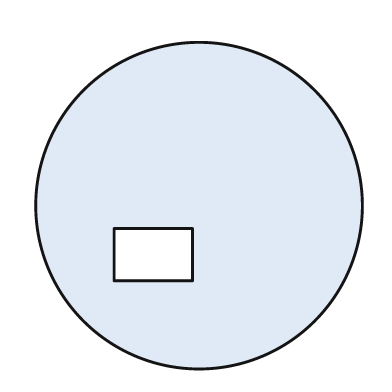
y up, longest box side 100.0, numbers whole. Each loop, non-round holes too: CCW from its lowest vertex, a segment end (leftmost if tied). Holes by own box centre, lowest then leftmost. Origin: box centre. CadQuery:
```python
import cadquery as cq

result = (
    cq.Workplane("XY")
    .moveTo(0.0, 0.0)
    .circle(50.0)
    .moveTo(-26.0, -23.0)
    .lineTo(-2.0, -23.0)
    .lineTo(-2.0, -7.0)
    .lineTo(-26.0, -7.0)
    .close()
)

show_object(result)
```